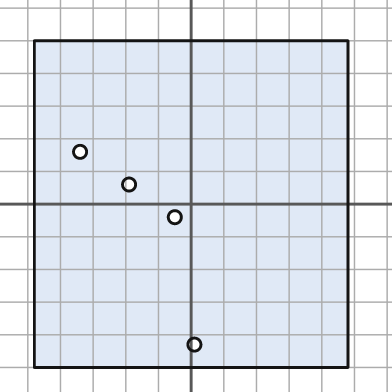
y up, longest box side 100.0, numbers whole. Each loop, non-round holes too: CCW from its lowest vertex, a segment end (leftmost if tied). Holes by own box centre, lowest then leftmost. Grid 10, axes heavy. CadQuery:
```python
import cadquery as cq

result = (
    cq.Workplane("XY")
    .moveTo(-48.0, -50.0)
    .lineTo(48.0, -50.0)
    .lineTo(48.0, 50.0)
    .lineTo(-48.0, 50.0)
    .close()
    .moveTo(1.0, -43.0)
    .circle(2.0)
    .moveTo(-5.0, -4.0)
    .circle(2.0)
    .moveTo(-19.0, 6.0)
    .circle(2.0)
    .moveTo(-34.0, 16.0)
    .circle(2.0)
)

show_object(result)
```